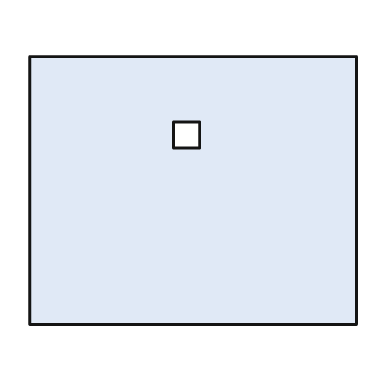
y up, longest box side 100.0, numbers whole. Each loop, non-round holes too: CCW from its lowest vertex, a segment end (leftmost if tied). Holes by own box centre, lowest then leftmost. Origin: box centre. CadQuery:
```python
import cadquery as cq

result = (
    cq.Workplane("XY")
    .moveTo(-50.0, -41.0)
    .lineTo(50.0, -41.0)
    .lineTo(50.0, 41.0)
    .lineTo(-50.0, 41.0)
    .close()
    .moveTo(-6.0, 13.0)
    .lineTo(2.0, 13.0)
    .lineTo(2.0, 21.0)
    .lineTo(-6.0, 21.0)
    .close()
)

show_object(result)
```